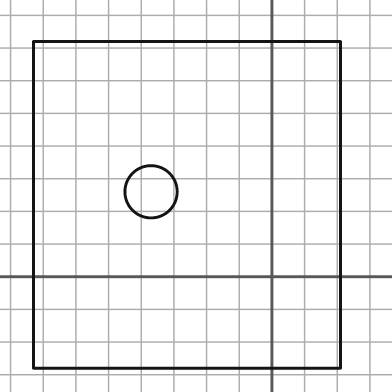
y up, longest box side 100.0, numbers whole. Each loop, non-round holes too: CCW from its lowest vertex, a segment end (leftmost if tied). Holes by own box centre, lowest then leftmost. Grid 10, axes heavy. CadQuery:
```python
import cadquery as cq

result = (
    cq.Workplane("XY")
    .moveTo(-73.0, -28.0)
    .lineTo(21.0, -28.0)
    .lineTo(21.0, 72.0)
    .lineTo(-73.0, 72.0)
    .close()
    .moveTo(-37.0, 26.0)
    .circle(8.0)
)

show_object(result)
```